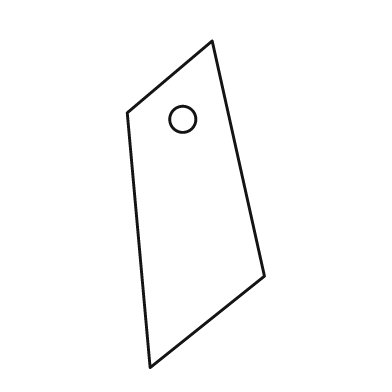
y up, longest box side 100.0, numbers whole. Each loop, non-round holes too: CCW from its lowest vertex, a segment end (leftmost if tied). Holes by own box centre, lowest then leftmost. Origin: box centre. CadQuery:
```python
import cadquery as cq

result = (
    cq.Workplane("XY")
    .moveTo(-14.0, -50.0)
    .lineTo(21.0, -22.0)
    .lineTo(5.0, 50.0)
    .lineTo(-21.0, 28.0)
    .close()
    .moveTo(-4.0, 26.0)
    .circle(4.0)
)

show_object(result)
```